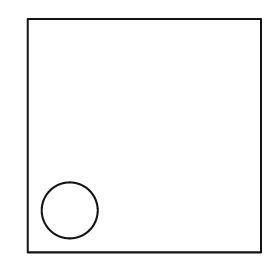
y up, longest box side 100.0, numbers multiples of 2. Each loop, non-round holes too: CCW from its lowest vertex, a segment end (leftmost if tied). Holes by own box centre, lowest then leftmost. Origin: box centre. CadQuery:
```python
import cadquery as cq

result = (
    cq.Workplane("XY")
    .moveTo(-50.0, -50.0)
    .lineTo(50.0, -50.0)
    .lineTo(50.0, 50.0)
    .lineTo(-50.0, 50.0)
    .close()
    .moveTo(-32.0, -32.0)
    .circle(12.0)
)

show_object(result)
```